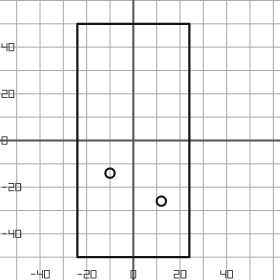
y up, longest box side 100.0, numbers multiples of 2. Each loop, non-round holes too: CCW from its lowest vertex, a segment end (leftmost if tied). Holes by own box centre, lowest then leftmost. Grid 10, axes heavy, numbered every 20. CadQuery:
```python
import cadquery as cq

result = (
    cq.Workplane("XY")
    .moveTo(-24.0, -50.0)
    .lineTo(24.0, -50.0)
    .lineTo(24.0, 50.0)
    .lineTo(-24.0, 50.0)
    .close()
    .moveTo(12.0, -26.0)
    .circle(2.0)
    .moveTo(-10.0, -14.0)
    .circle(2.0)
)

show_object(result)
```